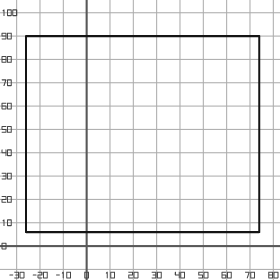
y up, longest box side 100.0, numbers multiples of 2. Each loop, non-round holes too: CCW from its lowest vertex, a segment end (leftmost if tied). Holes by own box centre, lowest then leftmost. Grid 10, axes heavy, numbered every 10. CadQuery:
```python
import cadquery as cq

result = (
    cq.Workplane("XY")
    .moveTo(-26.0, 6.0)
    .lineTo(74.0, 6.0)
    .lineTo(74.0, 90.0)
    .lineTo(-26.0, 90.0)
    .close()
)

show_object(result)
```